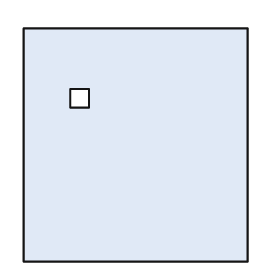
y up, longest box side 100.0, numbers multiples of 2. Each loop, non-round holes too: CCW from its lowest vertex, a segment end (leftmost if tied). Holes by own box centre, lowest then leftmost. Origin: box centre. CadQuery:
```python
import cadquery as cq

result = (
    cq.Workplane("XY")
    .moveTo(-48.0, -50.0)
    .lineTo(48.0, -50.0)
    .lineTo(48.0, 50.0)
    .lineTo(-48.0, 50.0)
    .close()
    .moveTo(-28.0, 16.0)
    .lineTo(-20.0, 16.0)
    .lineTo(-20.0, 24.0)
    .lineTo(-28.0, 24.0)
    .close()
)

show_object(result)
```